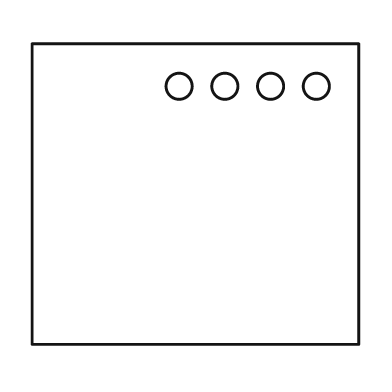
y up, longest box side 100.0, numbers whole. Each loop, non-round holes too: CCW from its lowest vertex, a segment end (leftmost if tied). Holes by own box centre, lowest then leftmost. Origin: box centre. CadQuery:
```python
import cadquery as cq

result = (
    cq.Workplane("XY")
    .moveTo(-50.0, -46.0)
    .lineTo(50.0, -46.0)
    .lineTo(50.0, 46.0)
    .lineTo(-50.0, 46.0)
    .close()
    .moveTo(-5.0, 33.0)
    .circle(4.0)
    .moveTo(9.0, 33.0)
    .circle(4.0)
    .moveTo(23.0, 33.0)
    .circle(4.0)
    .moveTo(37.0, 33.0)
    .circle(4.0)
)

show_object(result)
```